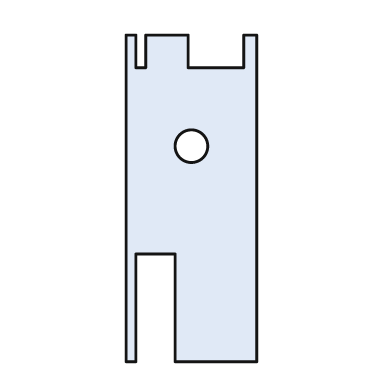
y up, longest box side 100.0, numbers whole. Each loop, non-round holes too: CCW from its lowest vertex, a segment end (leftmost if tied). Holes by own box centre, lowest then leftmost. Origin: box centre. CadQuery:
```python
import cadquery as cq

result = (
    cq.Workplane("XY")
    .moveTo(-20.0, -50.0)
    .lineTo(-17.0, -50.0)
    .lineTo(-17.0, -17.0)
    .lineTo(-5.0, -17.0)
    .lineTo(-5.0, -50.0)
    .lineTo(20.0, -50.0)
    .lineTo(20.0, 50.0)
    .lineTo(16.0, 50.0)
    .lineTo(16.0, 40.0)
    .lineTo(-1.0, 40.0)
    .lineTo(-1.0, 50.0)
    .lineTo(-14.0, 50.0)
    .lineTo(-14.0, 40.0)
    .lineTo(-17.0, 40.0)
    .lineTo(-17.0, 50.0)
    .lineTo(-20.0, 50.0)
    .close()
    .moveTo(0.0, 16.0)
    .circle(5.0)
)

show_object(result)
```